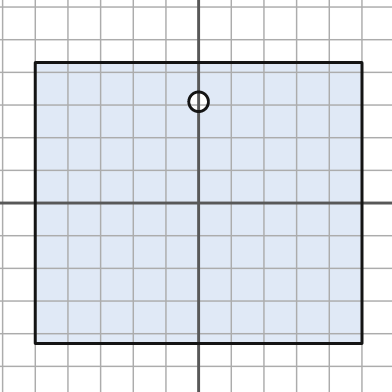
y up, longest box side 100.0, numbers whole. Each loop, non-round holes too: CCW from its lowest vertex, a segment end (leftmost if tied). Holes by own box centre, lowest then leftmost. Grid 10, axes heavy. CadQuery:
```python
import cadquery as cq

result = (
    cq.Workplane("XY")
    .moveTo(-50.0, -43.0)
    .lineTo(50.0, -43.0)
    .lineTo(50.0, 43.0)
    .lineTo(-50.0, 43.0)
    .close()
    .moveTo(0.0, 31.0)
    .circle(3.0)
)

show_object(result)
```